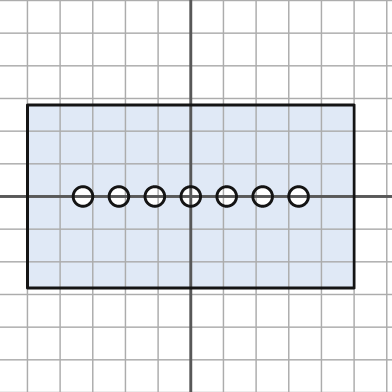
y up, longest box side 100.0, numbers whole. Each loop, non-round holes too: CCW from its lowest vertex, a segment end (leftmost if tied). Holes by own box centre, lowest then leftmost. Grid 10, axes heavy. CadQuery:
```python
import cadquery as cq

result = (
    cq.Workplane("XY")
    .moveTo(-50.0, -28.0)
    .lineTo(50.0, -28.0)
    .lineTo(50.0, 28.0)
    .lineTo(-50.0, 28.0)
    .close()
    .moveTo(-33.0, 0.0)
    .circle(3.0)
    .moveTo(-22.0, 0.0)
    .circle(3.0)
    .moveTo(-11.0, 0.0)
    .circle(3.0)
    .moveTo(0.0, 0.0)
    .circle(3.0)
    .moveTo(11.0, 0.0)
    .circle(3.0)
    .moveTo(22.0, 0.0)
    .circle(3.0)
    .moveTo(33.0, 0.0)
    .circle(3.0)
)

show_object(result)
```